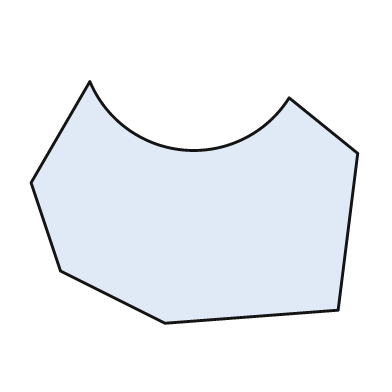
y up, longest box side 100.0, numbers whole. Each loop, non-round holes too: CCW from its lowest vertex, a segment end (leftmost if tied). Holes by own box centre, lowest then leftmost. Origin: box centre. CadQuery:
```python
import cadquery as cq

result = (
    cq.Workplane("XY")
    .moveTo(-9.0, -37.0)
    .lineTo(44.0, -33.0)
    .lineTo(50.0, 15.0)
    .lineTo(29.0, 32.0)
    .threePointArc((-3.0, 16.0), (-32.0, 37.0))
    .lineTo(-50.0, 6.0)
    .lineTo(-41.0, -21.0)
    .close()
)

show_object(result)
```